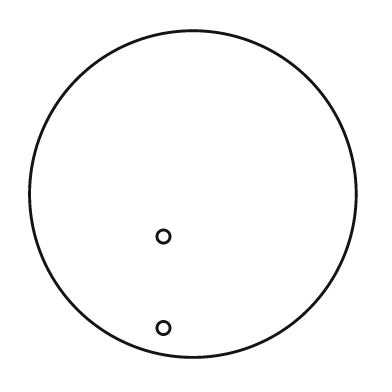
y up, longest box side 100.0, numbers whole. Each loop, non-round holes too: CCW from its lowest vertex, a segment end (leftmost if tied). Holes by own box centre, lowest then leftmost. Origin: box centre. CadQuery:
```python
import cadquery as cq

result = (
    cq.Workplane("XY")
    .moveTo(0.0, 0.0)
    .circle(50.0)
    .moveTo(-9.0, -41.0)
    .circle(2.0)
    .moveTo(-9.0, -13.0)
    .circle(2.0)
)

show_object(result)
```